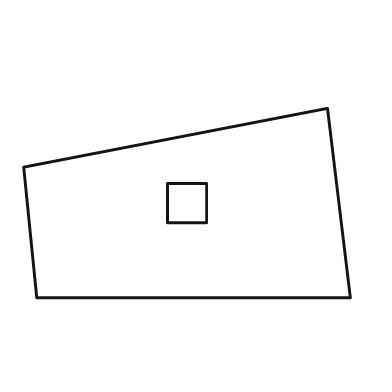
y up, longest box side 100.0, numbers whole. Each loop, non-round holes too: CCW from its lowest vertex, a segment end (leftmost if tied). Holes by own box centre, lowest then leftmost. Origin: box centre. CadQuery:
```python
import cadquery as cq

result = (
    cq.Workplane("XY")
    .moveTo(-46.0, -29.0)
    .lineTo(50.0, -29.0)
    .lineTo(43.0, 29.0)
    .lineTo(-50.0, 11.0)
    .close()
    .moveTo(-6.0, -6.0)
    .lineTo(6.0, -6.0)
    .lineTo(6.0, 6.0)
    .lineTo(-6.0, 6.0)
    .close()
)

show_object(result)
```